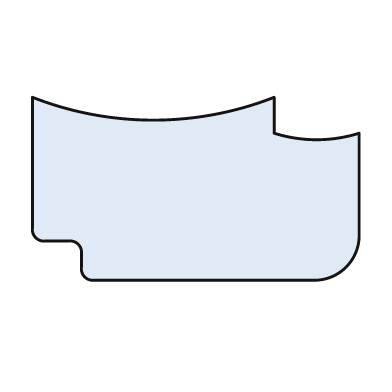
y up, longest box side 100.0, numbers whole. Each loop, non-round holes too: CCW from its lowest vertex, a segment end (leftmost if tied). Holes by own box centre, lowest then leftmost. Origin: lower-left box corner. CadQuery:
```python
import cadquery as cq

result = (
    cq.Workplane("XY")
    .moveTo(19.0, 0.0)
    .lineTo(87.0, 0.0)
    .threePointArc((96.0, 4.0), (100.0, 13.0))
    .lineTo(100.0, 45.0)
    .threePointArc((87.0, 43.0), (74.0, 45.0))
    .lineTo(74.0, 56.0)
    .threePointArc((37.0, 49.0), (0.0, 56.0))
    .lineTo(0.0, 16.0)
    .threePointArc((1.0, 13.0), (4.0, 12.0))
    .lineTo(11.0, 12.0)
    .threePointArc((14.0, 11.0), (15.0, 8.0))
    .lineTo(15.0, 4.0)
    .threePointArc((16.0, 1.0), (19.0, 0.0))
    .close()
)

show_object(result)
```